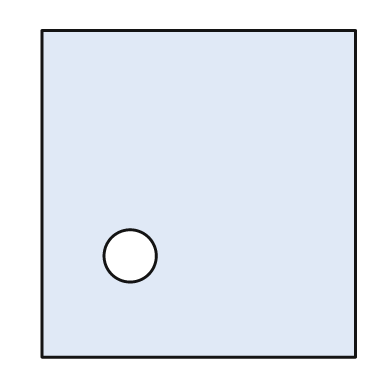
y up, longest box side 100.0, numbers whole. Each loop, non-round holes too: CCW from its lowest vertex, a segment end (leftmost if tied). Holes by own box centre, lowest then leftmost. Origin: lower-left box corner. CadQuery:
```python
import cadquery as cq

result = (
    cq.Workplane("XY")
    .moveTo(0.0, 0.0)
    .lineTo(96.0, 0.0)
    .lineTo(96.0, 100.0)
    .lineTo(0.0, 100.0)
    .close()
    .moveTo(27.0, 31.0)
    .circle(8.0)
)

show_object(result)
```